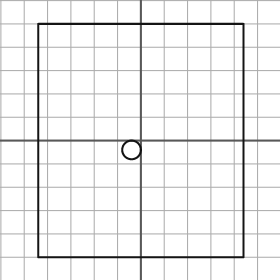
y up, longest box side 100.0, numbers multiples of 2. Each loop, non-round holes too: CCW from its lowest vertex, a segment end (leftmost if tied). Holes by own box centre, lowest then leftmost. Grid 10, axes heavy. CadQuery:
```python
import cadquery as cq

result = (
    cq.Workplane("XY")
    .moveTo(-44.0, -50.0)
    .lineTo(44.0, -50.0)
    .lineTo(44.0, 50.0)
    .lineTo(-44.0, 50.0)
    .close()
    .moveTo(-4.0, -4.0)
    .circle(4.0)
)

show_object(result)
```